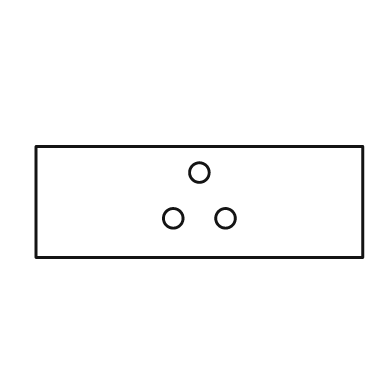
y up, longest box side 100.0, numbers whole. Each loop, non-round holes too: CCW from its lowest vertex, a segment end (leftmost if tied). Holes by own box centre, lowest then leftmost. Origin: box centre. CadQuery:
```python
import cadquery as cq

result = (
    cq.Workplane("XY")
    .moveTo(-50.0, -17.0)
    .lineTo(50.0, -17.0)
    .lineTo(50.0, 17.0)
    .lineTo(-50.0, 17.0)
    .close()
    .moveTo(-8.0, -5.0)
    .circle(3.0)
    .moveTo(8.0, -5.0)
    .circle(3.0)
    .moveTo(0.0, 9.0)
    .circle(3.0)
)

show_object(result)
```